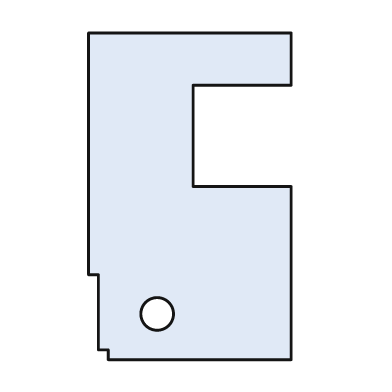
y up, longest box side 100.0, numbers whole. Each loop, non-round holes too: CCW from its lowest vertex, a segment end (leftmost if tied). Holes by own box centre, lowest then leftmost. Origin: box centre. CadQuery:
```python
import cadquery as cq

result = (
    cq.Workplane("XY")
    .moveTo(-25.0, -50.0)
    .lineTo(31.0, -50.0)
    .lineTo(31.0, 3.0)
    .lineTo(1.0, 3.0)
    .lineTo(1.0, 34.0)
    .lineTo(31.0, 34.0)
    .lineTo(31.0, 50.0)
    .lineTo(-31.0, 50.0)
    .lineTo(-31.0, -24.0)
    .lineTo(-28.0, -24.0)
    .lineTo(-28.0, -47.0)
    .lineTo(-25.0, -47.0)
    .close()
    .moveTo(-10.0, -36.0)
    .circle(5.0)
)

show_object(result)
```